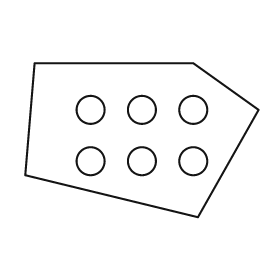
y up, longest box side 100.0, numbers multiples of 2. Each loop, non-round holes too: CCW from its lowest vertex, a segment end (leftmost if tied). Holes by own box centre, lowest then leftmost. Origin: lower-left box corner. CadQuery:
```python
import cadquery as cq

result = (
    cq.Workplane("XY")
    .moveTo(74.0, 0.0)
    .lineTo(100.0, 46.0)
    .lineTo(72.0, 66.0)
    .lineTo(4.0, 66.0)
    .lineTo(0.0, 18.0)
    .close()
    .moveTo(28.0, 24.0)
    .circle(6.0)
    .moveTo(50.0, 24.0)
    .circle(6.0)
    .moveTo(72.0, 24.0)
    .circle(6.0)
    .moveTo(28.0, 46.0)
    .circle(6.0)
    .moveTo(50.0, 46.0)
    .circle(6.0)
    .moveTo(72.0, 46.0)
    .circle(6.0)
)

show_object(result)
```